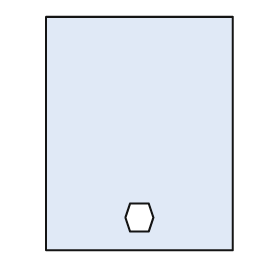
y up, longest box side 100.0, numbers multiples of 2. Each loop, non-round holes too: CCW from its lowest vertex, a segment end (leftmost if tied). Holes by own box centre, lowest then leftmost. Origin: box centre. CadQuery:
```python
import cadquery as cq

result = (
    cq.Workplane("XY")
    .moveTo(-40.0, -50.0)
    .lineTo(40.0, -50.0)
    .lineTo(40.0, 50.0)
    .lineTo(-40.0, 50.0)
    .close()
    .moveTo(-4.0, -42.0)
    .lineTo(4.0, -42.0)
    .lineTo(6.0, -36.0)
    .lineTo(4.0, -30.0)
    .lineTo(-4.0, -30.0)
    .lineTo(-6.0, -36.0)
    .close()
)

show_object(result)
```